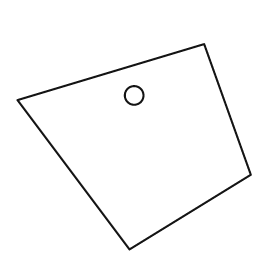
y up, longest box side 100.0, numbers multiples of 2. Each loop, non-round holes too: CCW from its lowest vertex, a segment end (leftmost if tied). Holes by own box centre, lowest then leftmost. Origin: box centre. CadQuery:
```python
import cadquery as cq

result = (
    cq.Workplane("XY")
    .moveTo(-2.0, -44.0)
    .lineTo(50.0, -12.0)
    .lineTo(30.0, 44.0)
    .lineTo(-50.0, 20.0)
    .close()
    .moveTo(0.0, 22.0)
    .circle(4.0)
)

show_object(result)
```